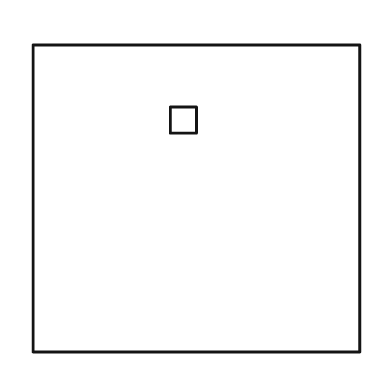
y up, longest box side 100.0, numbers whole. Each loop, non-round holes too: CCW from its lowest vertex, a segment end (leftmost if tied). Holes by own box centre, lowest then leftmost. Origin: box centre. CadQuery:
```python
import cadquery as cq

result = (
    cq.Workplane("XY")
    .moveTo(-50.0, -47.0)
    .lineTo(50.0, -47.0)
    .lineTo(50.0, 47.0)
    .lineTo(-50.0, 47.0)
    .close()
    .moveTo(-8.0, 20.0)
    .lineTo(0.0, 20.0)
    .lineTo(0.0, 28.0)
    .lineTo(-8.0, 28.0)
    .close()
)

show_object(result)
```